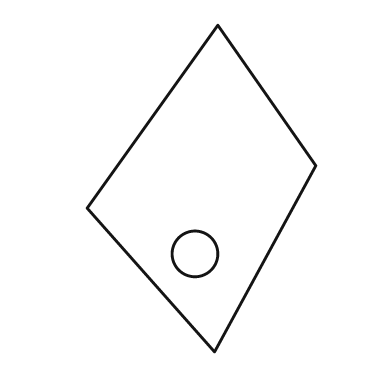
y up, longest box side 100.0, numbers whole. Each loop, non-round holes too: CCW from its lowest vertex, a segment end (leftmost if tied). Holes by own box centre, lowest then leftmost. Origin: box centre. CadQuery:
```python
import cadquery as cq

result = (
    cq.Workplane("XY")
    .moveTo(4.0, -50.0)
    .lineTo(35.0, 7.0)
    .lineTo(5.0, 50.0)
    .lineTo(-35.0, -6.0)
    .close()
    .moveTo(-2.0, -20.0)
    .circle(7.0)
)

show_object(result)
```